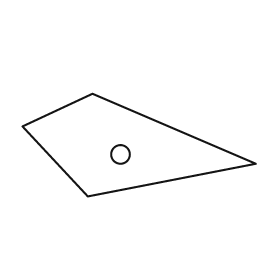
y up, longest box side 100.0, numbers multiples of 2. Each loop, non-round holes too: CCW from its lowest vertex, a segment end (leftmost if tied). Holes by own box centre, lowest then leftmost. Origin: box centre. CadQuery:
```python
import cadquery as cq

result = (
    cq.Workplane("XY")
    .moveTo(-22.0, -22.0)
    .lineTo(50.0, -8.0)
    .lineTo(-20.0, 22.0)
    .lineTo(-50.0, 8.0)
    .close()
    .moveTo(-8.0, -4.0)
    .circle(4.0)
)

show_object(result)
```